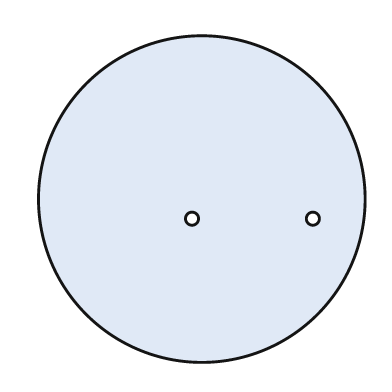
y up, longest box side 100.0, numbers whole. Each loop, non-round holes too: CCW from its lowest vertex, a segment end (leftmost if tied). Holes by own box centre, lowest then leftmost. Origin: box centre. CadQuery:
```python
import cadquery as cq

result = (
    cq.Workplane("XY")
    .moveTo(0.0, 0.0)
    .circle(50.0)
    .moveTo(-3.0, -6.0)
    .circle(2.0)
    .moveTo(34.0, -6.0)
    .circle(2.0)
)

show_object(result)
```